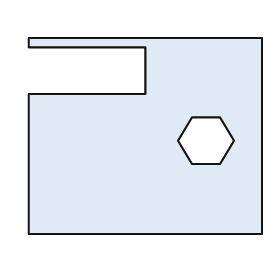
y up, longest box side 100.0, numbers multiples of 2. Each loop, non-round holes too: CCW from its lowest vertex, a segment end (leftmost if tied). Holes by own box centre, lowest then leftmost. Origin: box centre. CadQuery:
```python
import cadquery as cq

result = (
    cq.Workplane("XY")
    .moveTo(-50.0, -42.0)
    .lineTo(50.0, -42.0)
    .lineTo(50.0, 42.0)
    .lineTo(-50.0, 42.0)
    .lineTo(-50.0, 38.0)
    .lineTo(0.0, 38.0)
    .lineTo(0.0, 18.0)
    .lineTo(-50.0, 18.0)
    .close()
    .moveTo(20.0, -12.0)
    .lineTo(32.0, -12.0)
    .lineTo(38.0, -2.0)
    .lineTo(32.0, 8.0)
    .lineTo(20.0, 8.0)
    .lineTo(14.0, -2.0)
    .close()
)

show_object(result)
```